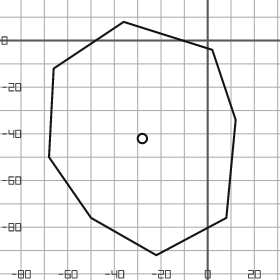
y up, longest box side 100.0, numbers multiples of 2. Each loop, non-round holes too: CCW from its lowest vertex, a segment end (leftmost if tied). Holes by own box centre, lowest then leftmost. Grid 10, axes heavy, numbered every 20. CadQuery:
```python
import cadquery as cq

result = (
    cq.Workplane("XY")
    .moveTo(-22.0, -92.0)
    .lineTo(8.0, -76.0)
    .lineTo(12.0, -34.0)
    .lineTo(2.0, -4.0)
    .lineTo(-36.0, 8.0)
    .lineTo(-66.0, -12.0)
    .lineTo(-68.0, -50.0)
    .lineTo(-50.0, -76.0)
    .close()
    .moveTo(-28.0, -42.0)
    .circle(2.0)
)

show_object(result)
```